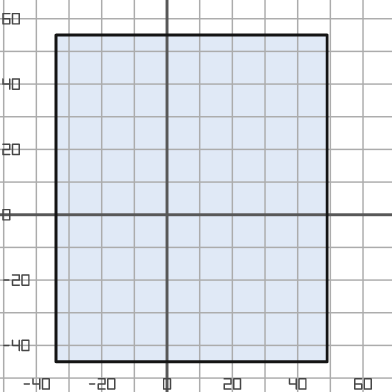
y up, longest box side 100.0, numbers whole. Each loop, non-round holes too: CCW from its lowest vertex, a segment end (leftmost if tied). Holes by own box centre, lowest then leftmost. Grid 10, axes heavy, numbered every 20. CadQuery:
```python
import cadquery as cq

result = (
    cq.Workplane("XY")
    .moveTo(-34.0, -45.0)
    .lineTo(49.0, -45.0)
    .lineTo(49.0, 55.0)
    .lineTo(-34.0, 55.0)
    .close()
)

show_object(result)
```